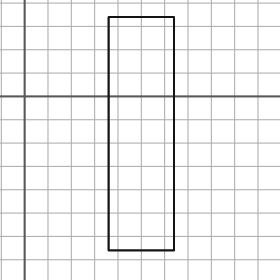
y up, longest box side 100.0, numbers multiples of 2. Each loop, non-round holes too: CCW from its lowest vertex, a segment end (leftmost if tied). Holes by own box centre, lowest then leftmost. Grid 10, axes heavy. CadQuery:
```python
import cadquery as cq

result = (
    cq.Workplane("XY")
    .moveTo(36.0, -66.0)
    .lineTo(64.0, -66.0)
    .lineTo(64.0, 34.0)
    .lineTo(36.0, 34.0)
    .close()
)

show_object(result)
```